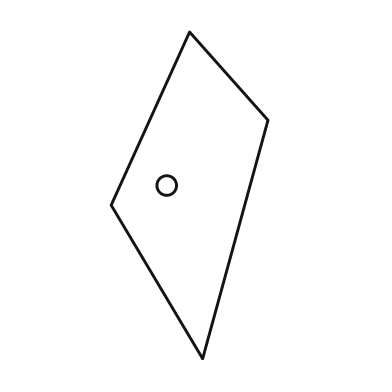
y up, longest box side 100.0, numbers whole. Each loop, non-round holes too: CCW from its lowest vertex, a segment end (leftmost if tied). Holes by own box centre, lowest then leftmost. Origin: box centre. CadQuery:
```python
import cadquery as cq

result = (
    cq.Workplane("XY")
    .moveTo(4.0, -50.0)
    .lineTo(24.0, 23.0)
    .lineTo(0.0, 50.0)
    .lineTo(-24.0, -3.0)
    .close()
    .moveTo(-7.0, 3.0)
    .circle(3.0)
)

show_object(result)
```